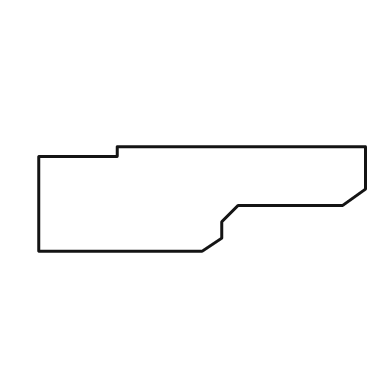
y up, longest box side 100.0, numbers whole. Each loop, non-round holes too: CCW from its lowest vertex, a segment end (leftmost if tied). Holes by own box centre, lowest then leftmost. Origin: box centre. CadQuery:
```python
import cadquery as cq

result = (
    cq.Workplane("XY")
    .moveTo(-50.0, -16.0)
    .lineTo(0.0, -16.0)
    .lineTo(6.0, -12.0)
    .lineTo(6.0, -7.0)
    .lineTo(11.0, -2.0)
    .lineTo(43.0, -2.0)
    .lineTo(50.0, 3.0)
    .lineTo(50.0, 16.0)
    .lineTo(-26.0, 16.0)
    .lineTo(-26.0, 13.0)
    .lineTo(-50.0, 13.0)
    .close()
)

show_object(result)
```